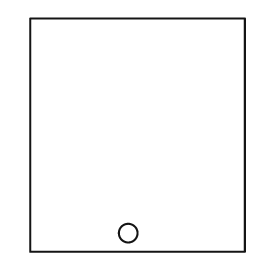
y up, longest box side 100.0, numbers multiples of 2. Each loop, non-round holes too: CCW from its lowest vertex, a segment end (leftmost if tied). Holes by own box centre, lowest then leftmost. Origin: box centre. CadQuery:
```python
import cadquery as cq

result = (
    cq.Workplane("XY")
    .moveTo(-46.0, -50.0)
    .lineTo(46.0, -50.0)
    .lineTo(46.0, 50.0)
    .lineTo(-46.0, 50.0)
    .close()
    .moveTo(-4.0, -42.0)
    .circle(4.0)
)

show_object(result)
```